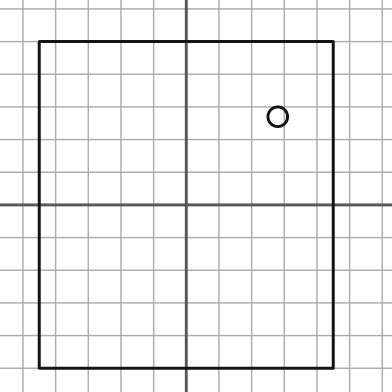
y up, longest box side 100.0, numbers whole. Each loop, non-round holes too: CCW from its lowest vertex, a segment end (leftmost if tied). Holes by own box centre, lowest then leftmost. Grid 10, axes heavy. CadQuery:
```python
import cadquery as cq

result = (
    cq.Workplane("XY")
    .moveTo(-45.0, -50.0)
    .lineTo(45.0, -50.0)
    .lineTo(45.0, 50.0)
    .lineTo(-45.0, 50.0)
    .close()
    .moveTo(28.0, 27.0)
    .circle(3.0)
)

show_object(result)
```